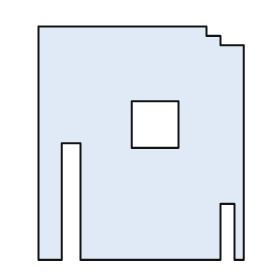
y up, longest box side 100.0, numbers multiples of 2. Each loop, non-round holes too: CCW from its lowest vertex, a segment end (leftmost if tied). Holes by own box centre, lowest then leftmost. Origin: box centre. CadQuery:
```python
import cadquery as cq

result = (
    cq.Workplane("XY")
    .moveTo(-44.0, -50.0)
    .lineTo(-34.0, -50.0)
    .lineTo(-34.0, 0.0)
    .lineTo(-26.0, 0.0)
    .lineTo(-26.0, -50.0)
    .lineTo(34.0, -50.0)
    .lineTo(34.0, -26.0)
    .lineTo(40.0, -26.0)
    .lineTo(40.0, -50.0)
    .lineTo(44.0, -50.0)
    .lineTo(44.0, 42.0)
    .lineTo(34.0, 42.0)
    .lineTo(34.0, 46.0)
    .lineTo(28.0, 46.0)
    .lineTo(28.0, 50.0)
    .lineTo(-44.0, 50.0)
    .close()
    .moveTo(-4.0, -2.0)
    .lineTo(16.0, -2.0)
    .lineTo(16.0, 18.0)
    .lineTo(-4.0, 18.0)
    .close()
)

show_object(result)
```